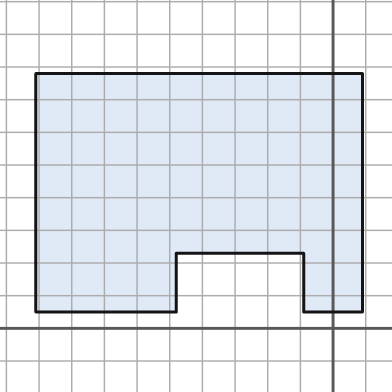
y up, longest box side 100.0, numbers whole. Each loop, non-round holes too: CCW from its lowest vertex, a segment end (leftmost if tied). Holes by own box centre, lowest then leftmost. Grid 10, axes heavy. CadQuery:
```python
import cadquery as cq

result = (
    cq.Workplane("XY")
    .moveTo(-91.0, 5.0)
    .lineTo(-48.0, 5.0)
    .lineTo(-48.0, 23.0)
    .lineTo(-9.0, 23.0)
    .lineTo(-9.0, 5.0)
    .lineTo(9.0, 5.0)
    .lineTo(9.0, 78.0)
    .lineTo(-91.0, 78.0)
    .close()
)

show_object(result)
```